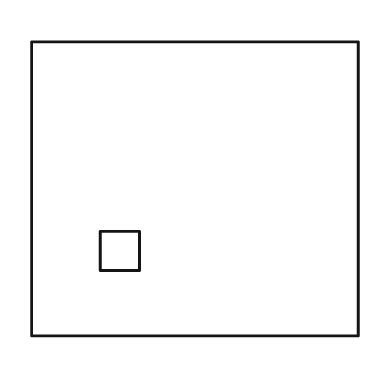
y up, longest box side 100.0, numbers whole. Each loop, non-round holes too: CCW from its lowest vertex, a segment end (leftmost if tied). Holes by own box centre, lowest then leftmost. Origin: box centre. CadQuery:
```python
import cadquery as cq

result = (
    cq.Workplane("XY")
    .moveTo(-50.0, -45.0)
    .lineTo(50.0, -45.0)
    .lineTo(50.0, 45.0)
    .lineTo(-50.0, 45.0)
    .close()
    .moveTo(-29.0, -25.0)
    .lineTo(-17.0, -25.0)
    .lineTo(-17.0, -13.0)
    .lineTo(-29.0, -13.0)
    .close()
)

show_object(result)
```